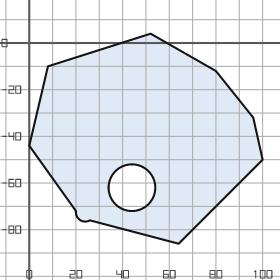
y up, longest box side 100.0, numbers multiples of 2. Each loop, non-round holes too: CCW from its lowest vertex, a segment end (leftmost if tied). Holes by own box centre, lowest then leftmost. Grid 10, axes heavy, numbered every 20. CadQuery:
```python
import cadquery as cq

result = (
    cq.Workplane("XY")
    .moveTo(64.0, -86.0)
    .lineTo(100.0, -50.0)
    .lineTo(96.0, -32.0)
    .lineTo(80.0, -12.0)
    .lineTo(52.0, 4.0)
    .lineTo(8.0, -10.0)
    .lineTo(0.0, -44.0)
    .lineTo(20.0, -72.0)
    .threePointArc((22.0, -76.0), (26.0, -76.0))
    .close()
    .moveTo(44.0, -62.0)
    .circle(10.0)
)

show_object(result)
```